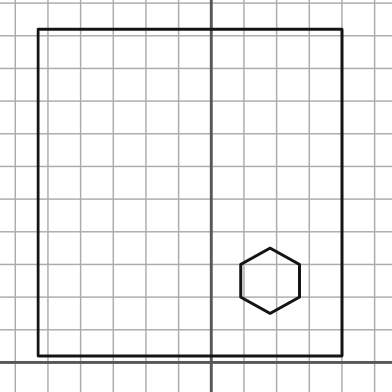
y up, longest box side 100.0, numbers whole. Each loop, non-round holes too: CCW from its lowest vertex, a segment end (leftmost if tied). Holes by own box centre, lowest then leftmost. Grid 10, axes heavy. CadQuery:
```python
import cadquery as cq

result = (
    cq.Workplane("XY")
    .moveTo(-53.0, 2.0)
    .lineTo(40.0, 2.0)
    .lineTo(40.0, 102.0)
    .lineTo(-53.0, 102.0)
    .close()
    .moveTo(18.0, 15.0)
    .lineTo(27.0, 20.0)
    .lineTo(27.0, 30.0)
    .lineTo(18.0, 35.0)
    .lineTo(9.0, 30.0)
    .lineTo(9.0, 20.0)
    .close()
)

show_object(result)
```